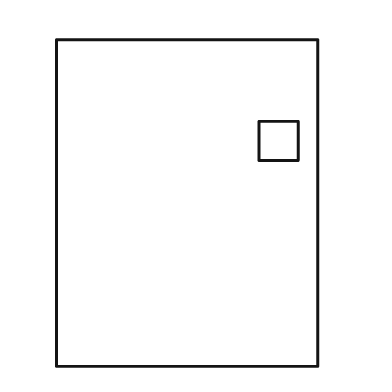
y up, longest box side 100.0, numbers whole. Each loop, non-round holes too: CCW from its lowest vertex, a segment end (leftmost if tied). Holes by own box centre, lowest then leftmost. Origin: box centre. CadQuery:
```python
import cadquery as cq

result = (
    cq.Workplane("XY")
    .moveTo(-40.0, -50.0)
    .lineTo(40.0, -50.0)
    .lineTo(40.0, 50.0)
    .lineTo(-40.0, 50.0)
    .close()
    .moveTo(22.0, 13.0)
    .lineTo(34.0, 13.0)
    .lineTo(34.0, 25.0)
    .lineTo(22.0, 25.0)
    .close()
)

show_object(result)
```